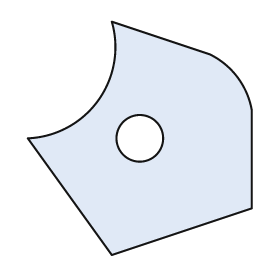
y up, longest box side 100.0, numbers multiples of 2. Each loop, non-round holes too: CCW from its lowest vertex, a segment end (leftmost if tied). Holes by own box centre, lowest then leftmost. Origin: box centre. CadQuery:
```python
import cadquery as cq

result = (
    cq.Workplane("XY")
    .moveTo(-12.0, -50.0)
    .lineTo(48.0, -30.0)
    .lineTo(48.0, 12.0)
    .threePointArc((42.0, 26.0), (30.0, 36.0))
    .lineTo(-12.0, 50.0)
    .threePointArc((-18.0, 16.0), (-48.0, 0.0))
    .close()
    .moveTo(0.0, 0.0)
    .circle(10.0)
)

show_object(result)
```